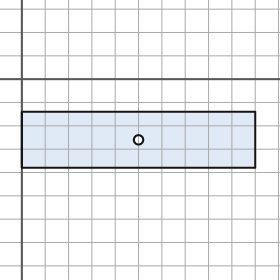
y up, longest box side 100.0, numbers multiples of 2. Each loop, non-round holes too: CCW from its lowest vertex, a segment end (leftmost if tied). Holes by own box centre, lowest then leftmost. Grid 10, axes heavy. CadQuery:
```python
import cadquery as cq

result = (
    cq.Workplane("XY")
    .moveTo(0.0, -38.0)
    .lineTo(100.0, -38.0)
    .lineTo(100.0, -14.0)
    .lineTo(0.0, -14.0)
    .close()
    .moveTo(50.0, -26.0)
    .circle(2.0)
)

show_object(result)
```